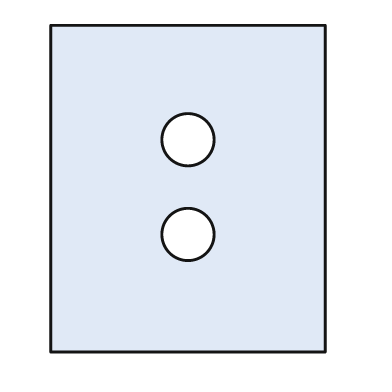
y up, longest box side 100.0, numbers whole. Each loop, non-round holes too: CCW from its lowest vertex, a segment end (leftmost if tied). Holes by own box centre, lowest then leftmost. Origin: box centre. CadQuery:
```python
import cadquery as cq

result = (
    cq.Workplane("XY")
    .moveTo(-42.0, -50.0)
    .lineTo(42.0, -50.0)
    .lineTo(42.0, 50.0)
    .lineTo(-42.0, 50.0)
    .close()
    .moveTo(0.0, -14.0)
    .circle(8.0)
    .moveTo(0.0, 15.0)
    .circle(8.0)
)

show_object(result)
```